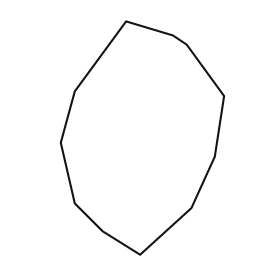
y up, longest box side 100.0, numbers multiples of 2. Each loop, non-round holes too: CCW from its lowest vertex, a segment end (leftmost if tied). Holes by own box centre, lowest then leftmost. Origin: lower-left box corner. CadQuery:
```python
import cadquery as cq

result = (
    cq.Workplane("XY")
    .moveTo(34.0, 0.0)
    .lineTo(56.0, 20.0)
    .lineTo(66.0, 42.0)
    .lineTo(70.0, 68.0)
    .lineTo(54.0, 90.0)
    .lineTo(48.0, 94.0)
    .lineTo(28.0, 100.0)
    .lineTo(6.0, 70.0)
    .lineTo(0.0, 48.0)
    .lineTo(6.0, 22.0)
    .lineTo(18.0, 10.0)
    .close()
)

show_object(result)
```